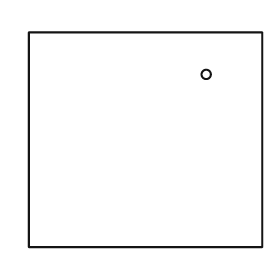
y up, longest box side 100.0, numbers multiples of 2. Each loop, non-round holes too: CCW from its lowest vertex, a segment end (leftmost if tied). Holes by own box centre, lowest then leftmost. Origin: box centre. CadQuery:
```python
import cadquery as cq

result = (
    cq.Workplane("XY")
    .moveTo(-50.0, -46.0)
    .lineTo(50.0, -46.0)
    .lineTo(50.0, 46.0)
    .lineTo(-50.0, 46.0)
    .close()
    .moveTo(26.0, 28.0)
    .circle(2.0)
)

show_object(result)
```